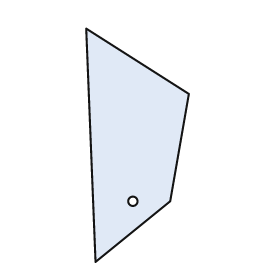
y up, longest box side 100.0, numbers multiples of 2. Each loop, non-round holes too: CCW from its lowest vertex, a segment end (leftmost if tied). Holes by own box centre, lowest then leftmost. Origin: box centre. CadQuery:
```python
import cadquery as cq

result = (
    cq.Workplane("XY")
    .moveTo(-18.0, -50.0)
    .lineTo(14.0, -24.0)
    .lineTo(22.0, 22.0)
    .lineTo(-22.0, 50.0)
    .close()
    .moveTo(-2.0, -24.0)
    .circle(2.0)
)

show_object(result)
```